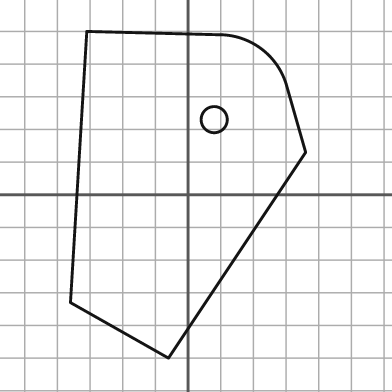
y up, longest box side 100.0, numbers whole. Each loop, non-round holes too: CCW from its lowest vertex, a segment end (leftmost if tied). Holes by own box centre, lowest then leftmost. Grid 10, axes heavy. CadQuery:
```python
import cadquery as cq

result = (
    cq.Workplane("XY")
    .moveTo(-6.0, -50.0)
    .lineTo(36.0, 13.0)
    .lineTo(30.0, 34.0)
    .threePointArc((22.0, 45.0), (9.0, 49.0))
    .lineTo(-31.0, 50.0)
    .lineTo(-36.0, -33.0)
    .close()
    .moveTo(8.0, 23.0)
    .circle(4.0)
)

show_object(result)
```